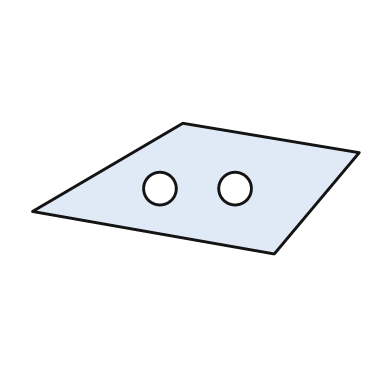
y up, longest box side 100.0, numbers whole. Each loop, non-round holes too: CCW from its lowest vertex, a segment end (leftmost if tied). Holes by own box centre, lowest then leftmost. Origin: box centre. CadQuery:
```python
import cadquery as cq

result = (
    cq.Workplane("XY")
    .moveTo(24.0, -20.0)
    .lineTo(50.0, 11.0)
    .lineTo(-4.0, 20.0)
    .lineTo(-50.0, -7.0)
    .close()
    .moveTo(-11.0, 0.0)
    .circle(5.0)
    .moveTo(12.0, 0.0)
    .circle(5.0)
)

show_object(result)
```